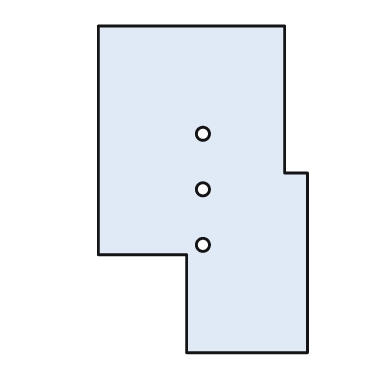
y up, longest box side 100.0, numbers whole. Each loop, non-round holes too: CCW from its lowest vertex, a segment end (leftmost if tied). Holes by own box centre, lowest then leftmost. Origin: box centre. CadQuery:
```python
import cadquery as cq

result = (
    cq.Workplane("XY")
    .moveTo(-5.0, -50.0)
    .lineTo(32.0, -50.0)
    .lineTo(32.0, 5.0)
    .lineTo(25.0, 5.0)
    .lineTo(25.0, 50.0)
    .lineTo(-32.0, 50.0)
    .lineTo(-32.0, -20.0)
    .lineTo(-5.0, -20.0)
    .close()
    .moveTo(0.0, -17.0)
    .circle(2.0)
    .moveTo(0.0, 0.0)
    .circle(2.0)
    .moveTo(0.0, 17.0)
    .circle(2.0)
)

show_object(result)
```